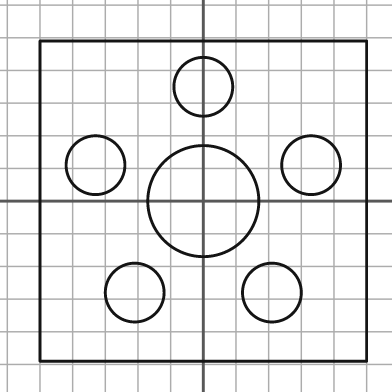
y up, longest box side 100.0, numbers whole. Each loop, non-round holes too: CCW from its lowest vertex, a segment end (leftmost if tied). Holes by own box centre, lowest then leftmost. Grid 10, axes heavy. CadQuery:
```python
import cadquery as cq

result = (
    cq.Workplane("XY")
    .moveTo(-50.0, -49.0)
    .lineTo(50.0, -49.0)
    .lineTo(50.0, 49.0)
    .lineTo(-50.0, 49.0)
    .close()
    .moveTo(-21.0, -28.0)
    .circle(9.0)
    .moveTo(21.0, -28.0)
    .circle(9.0)
    .moveTo(0.0, 0.0)
    .circle(17.0)
    .moveTo(-33.0, 11.0)
    .circle(9.0)
    .moveTo(33.0, 11.0)
    .circle(9.0)
    .moveTo(0.0, 35.0)
    .circle(9.0)
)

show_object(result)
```